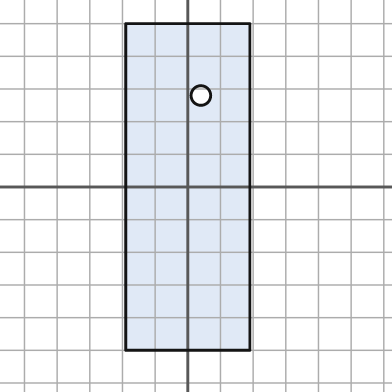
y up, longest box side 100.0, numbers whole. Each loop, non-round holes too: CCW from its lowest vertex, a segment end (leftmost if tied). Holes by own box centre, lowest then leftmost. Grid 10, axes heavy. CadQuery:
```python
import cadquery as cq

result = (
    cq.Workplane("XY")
    .moveTo(-19.0, -50.0)
    .lineTo(19.0, -50.0)
    .lineTo(19.0, 50.0)
    .lineTo(-19.0, 50.0)
    .close()
    .moveTo(4.0, 28.0)
    .circle(3.0)
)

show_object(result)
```